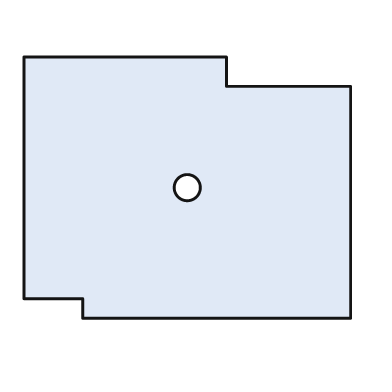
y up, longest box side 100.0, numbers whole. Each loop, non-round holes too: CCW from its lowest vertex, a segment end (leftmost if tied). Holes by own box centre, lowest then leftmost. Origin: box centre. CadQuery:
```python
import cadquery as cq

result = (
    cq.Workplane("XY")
    .moveTo(-32.0, -40.0)
    .lineTo(50.0, -40.0)
    .lineTo(50.0, 31.0)
    .lineTo(12.0, 31.0)
    .lineTo(12.0, 40.0)
    .lineTo(-50.0, 40.0)
    .lineTo(-50.0, -34.0)
    .lineTo(-32.0, -34.0)
    .close()
    .moveTo(0.0, 0.0)
    .circle(4.0)
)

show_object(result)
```